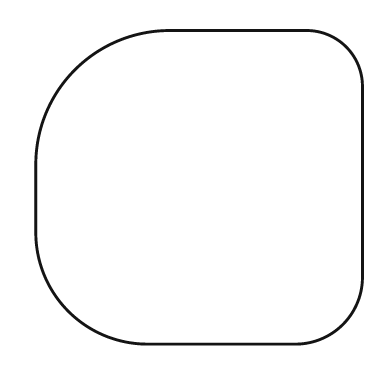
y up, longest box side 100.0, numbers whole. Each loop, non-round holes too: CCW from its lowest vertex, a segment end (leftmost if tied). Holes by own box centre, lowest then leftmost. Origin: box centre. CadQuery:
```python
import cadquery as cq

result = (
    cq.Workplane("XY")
    .moveTo(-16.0, -48.0)
    .lineTo(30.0, -48.0)
    .threePointArc((44.0, -42.0), (50.0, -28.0))
    .lineTo(50.0, 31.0)
    .threePointArc((45.0, 43.0), (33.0, 48.0))
    .lineTo(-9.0, 48.0)
    .threePointArc((-38.0, 36.0), (-50.0, 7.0))
    .lineTo(-50.0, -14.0)
    .threePointArc((-40.0, -38.0), (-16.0, -48.0))
    .close()
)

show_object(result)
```